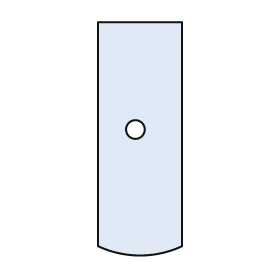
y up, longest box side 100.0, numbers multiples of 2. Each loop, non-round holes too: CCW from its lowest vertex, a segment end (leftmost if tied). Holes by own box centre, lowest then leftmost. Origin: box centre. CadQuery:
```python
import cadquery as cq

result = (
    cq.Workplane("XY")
    .moveTo(-18.0, -46.0)
    .threePointArc((0.0, -50.0), (18.0, -46.0))
    .lineTo(18.0, 50.0)
    .lineTo(-18.0, 50.0)
    .close()
    .moveTo(-2.0, 4.0)
    .circle(4.0)
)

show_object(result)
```